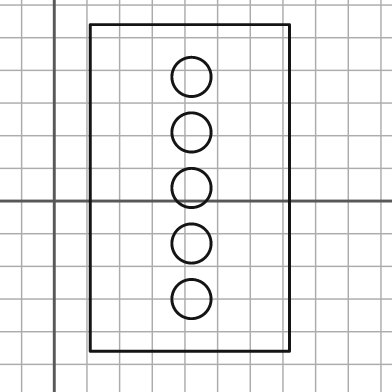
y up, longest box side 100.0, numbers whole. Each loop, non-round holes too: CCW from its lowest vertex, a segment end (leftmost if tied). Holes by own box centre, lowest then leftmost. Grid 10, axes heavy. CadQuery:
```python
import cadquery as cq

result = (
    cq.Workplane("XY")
    .moveTo(11.0, -46.0)
    .lineTo(72.0, -46.0)
    .lineTo(72.0, 54.0)
    .lineTo(11.0, 54.0)
    .close()
    .moveTo(42.0, -30.0)
    .circle(6.0)
    .moveTo(42.0, -13.0)
    .circle(6.0)
    .moveTo(42.0, 4.0)
    .circle(6.0)
    .moveTo(42.0, 21.0)
    .circle(6.0)
    .moveTo(42.0, 38.0)
    .circle(6.0)
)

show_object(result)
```